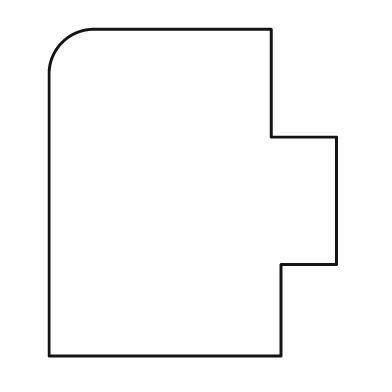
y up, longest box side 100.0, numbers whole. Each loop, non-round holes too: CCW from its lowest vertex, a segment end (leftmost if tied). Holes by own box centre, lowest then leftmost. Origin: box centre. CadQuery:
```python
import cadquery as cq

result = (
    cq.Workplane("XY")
    .moveTo(-44.0, -50.0)
    .lineTo(27.0, -50.0)
    .lineTo(27.0, -22.0)
    .lineTo(44.0, -22.0)
    .lineTo(44.0, 17.0)
    .lineTo(24.0, 17.0)
    .lineTo(24.0, 50.0)
    .lineTo(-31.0, 50.0)
    .threePointArc((-40.0, 46.0), (-44.0, 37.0))
    .close()
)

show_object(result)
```